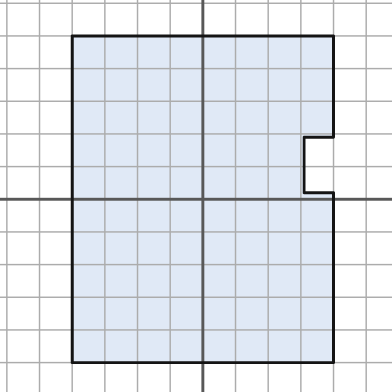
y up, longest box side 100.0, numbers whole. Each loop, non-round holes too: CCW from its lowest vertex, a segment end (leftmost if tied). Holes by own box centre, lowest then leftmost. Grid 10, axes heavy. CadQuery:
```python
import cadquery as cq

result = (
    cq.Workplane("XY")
    .moveTo(-40.0, -50.0)
    .lineTo(40.0, -50.0)
    .lineTo(40.0, 2.0)
    .lineTo(31.0, 2.0)
    .lineTo(31.0, 19.0)
    .lineTo(40.0, 19.0)
    .lineTo(40.0, 50.0)
    .lineTo(-40.0, 50.0)
    .close()
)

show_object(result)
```